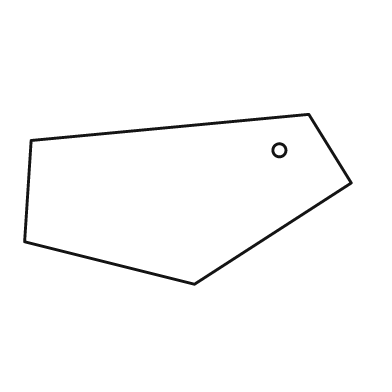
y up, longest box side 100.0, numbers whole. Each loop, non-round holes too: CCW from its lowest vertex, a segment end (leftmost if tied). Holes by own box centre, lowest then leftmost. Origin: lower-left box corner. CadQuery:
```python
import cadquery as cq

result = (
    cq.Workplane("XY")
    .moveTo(52.0, 0.0)
    .lineTo(100.0, 31.0)
    .lineTo(87.0, 52.0)
    .lineTo(2.0, 44.0)
    .lineTo(0.0, 13.0)
    .close()
    .moveTo(78.0, 41.0)
    .circle(2.0)
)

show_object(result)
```